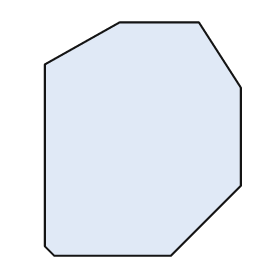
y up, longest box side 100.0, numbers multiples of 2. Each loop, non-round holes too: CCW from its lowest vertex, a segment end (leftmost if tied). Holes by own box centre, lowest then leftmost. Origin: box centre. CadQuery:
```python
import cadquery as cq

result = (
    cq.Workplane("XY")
    .moveTo(-38.0, -50.0)
    .lineTo(12.0, -50.0)
    .lineTo(42.0, -20.0)
    .lineTo(42.0, 22.0)
    .lineTo(24.0, 50.0)
    .lineTo(-10.0, 50.0)
    .lineTo(-42.0, 32.0)
    .lineTo(-42.0, -46.0)
    .close()
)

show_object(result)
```